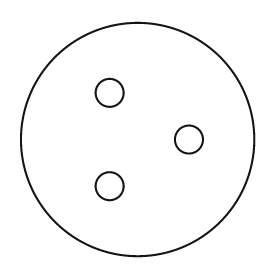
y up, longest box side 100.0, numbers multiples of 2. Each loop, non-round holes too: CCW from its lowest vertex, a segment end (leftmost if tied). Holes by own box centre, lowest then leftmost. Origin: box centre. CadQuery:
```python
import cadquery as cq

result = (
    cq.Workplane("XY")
    .moveTo(0.0, 0.0)
    .circle(50.0)
    .moveTo(-12.0, -20.0)
    .circle(6.0)
    .moveTo(22.0, 0.0)
    .circle(6.0)
    .moveTo(-12.0, 20.0)
    .circle(6.0)
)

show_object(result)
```